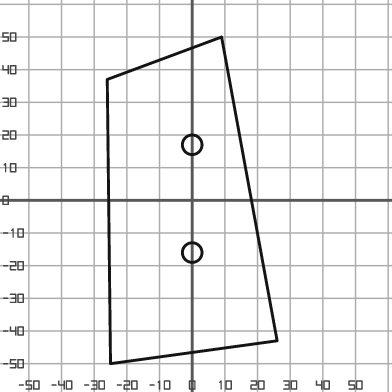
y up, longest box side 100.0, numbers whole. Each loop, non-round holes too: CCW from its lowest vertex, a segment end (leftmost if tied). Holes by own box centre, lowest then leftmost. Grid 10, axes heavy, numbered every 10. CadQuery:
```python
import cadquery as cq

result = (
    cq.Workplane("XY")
    .moveTo(-25.0, -50.0)
    .lineTo(26.0, -43.0)
    .lineTo(9.0, 50.0)
    .lineTo(-26.0, 37.0)
    .close()
    .moveTo(0.0, -16.0)
    .circle(3.0)
    .moveTo(0.0, 17.0)
    .circle(3.0)
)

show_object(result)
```